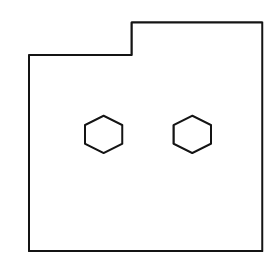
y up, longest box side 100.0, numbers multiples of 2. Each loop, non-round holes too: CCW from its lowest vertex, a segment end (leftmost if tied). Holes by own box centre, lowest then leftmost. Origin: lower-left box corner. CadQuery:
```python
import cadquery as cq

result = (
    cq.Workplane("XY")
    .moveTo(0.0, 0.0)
    .lineTo(100.0, 0.0)
    .lineTo(100.0, 98.0)
    .lineTo(44.0, 98.0)
    .lineTo(44.0, 84.0)
    .lineTo(0.0, 84.0)
    .close()
    .moveTo(32.0, 42.0)
    .lineTo(40.0, 46.0)
    .lineTo(40.0, 54.0)
    .lineTo(32.0, 58.0)
    .lineTo(24.0, 54.0)
    .lineTo(24.0, 46.0)
    .close()
    .moveTo(70.0, 42.0)
    .lineTo(78.0, 46.0)
    .lineTo(78.0, 54.0)
    .lineTo(70.0, 58.0)
    .lineTo(62.0, 54.0)
    .lineTo(62.0, 46.0)
    .close()
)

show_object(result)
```